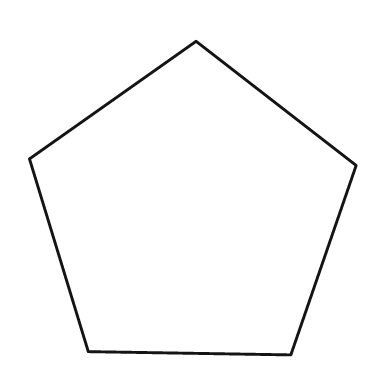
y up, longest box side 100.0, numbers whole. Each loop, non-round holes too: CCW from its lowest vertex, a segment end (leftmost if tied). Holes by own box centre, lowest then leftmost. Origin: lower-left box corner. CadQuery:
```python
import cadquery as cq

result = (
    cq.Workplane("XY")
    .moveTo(80.0, 0.0)
    .lineTo(100.0, 58.0)
    .lineTo(51.0, 96.0)
    .lineTo(0.0, 60.0)
    .lineTo(18.0, 1.0)
    .close()
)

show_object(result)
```